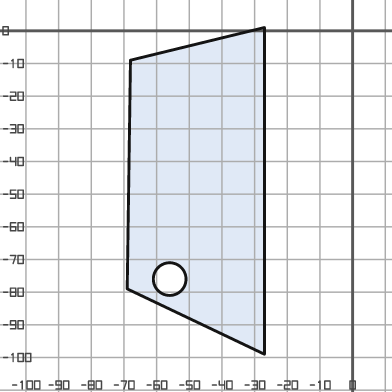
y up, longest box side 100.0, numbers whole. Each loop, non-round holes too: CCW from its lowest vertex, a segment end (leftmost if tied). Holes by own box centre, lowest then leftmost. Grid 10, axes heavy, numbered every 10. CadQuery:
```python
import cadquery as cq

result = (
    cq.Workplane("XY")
    .moveTo(-27.0, -99.0)
    .lineTo(-27.0, 1.0)
    .lineTo(-68.0, -9.0)
    .lineTo(-69.0, -79.0)
    .close()
    .moveTo(-56.0, -76.0)
    .circle(5.0)
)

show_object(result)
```